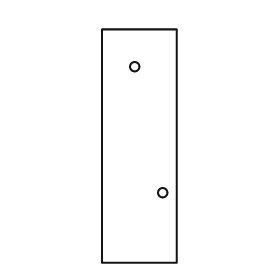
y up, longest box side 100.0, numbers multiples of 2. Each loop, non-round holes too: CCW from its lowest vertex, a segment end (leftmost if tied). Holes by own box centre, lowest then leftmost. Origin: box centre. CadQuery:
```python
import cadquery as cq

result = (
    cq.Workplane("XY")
    .moveTo(-16.0, -50.0)
    .lineTo(16.0, -50.0)
    .lineTo(16.0, 50.0)
    .lineTo(-16.0, 50.0)
    .close()
    .moveTo(10.0, -20.0)
    .circle(2.0)
    .moveTo(-2.0, 34.0)
    .circle(2.0)
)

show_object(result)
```